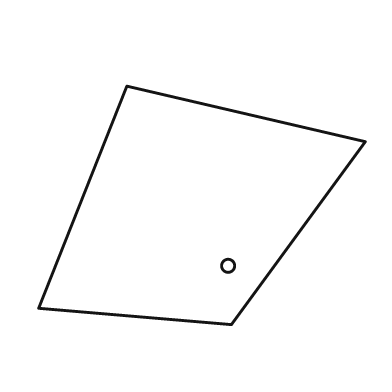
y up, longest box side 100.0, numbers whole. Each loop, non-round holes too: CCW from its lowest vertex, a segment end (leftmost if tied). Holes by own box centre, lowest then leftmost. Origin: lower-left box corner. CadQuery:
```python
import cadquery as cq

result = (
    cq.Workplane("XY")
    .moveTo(59.0, 0.0)
    .lineTo(100.0, 56.0)
    .lineTo(27.0, 73.0)
    .lineTo(0.0, 5.0)
    .close()
    .moveTo(58.0, 18.0)
    .circle(2.0)
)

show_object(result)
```